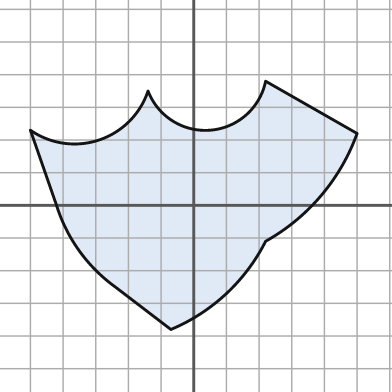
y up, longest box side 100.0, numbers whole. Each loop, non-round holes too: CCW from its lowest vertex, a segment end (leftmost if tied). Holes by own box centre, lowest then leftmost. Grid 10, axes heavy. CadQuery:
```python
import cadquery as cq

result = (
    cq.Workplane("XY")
    .moveTo(-7.0, -38.0)
    .threePointArc((10.0, -27.0), (22.0, -11.0))
    .threePointArc((39.0, 3.0), (50.0, 22.0))
    .lineTo(22.0, 38.0)
    .threePointArc((5.0, 23.0), (-14.0, 35.0))
    .threePointArc((-29.0, 20.0), (-50.0, 23.0))
    .lineTo(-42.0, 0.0)
    .threePointArc((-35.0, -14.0), (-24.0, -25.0))
    .close()
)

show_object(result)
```